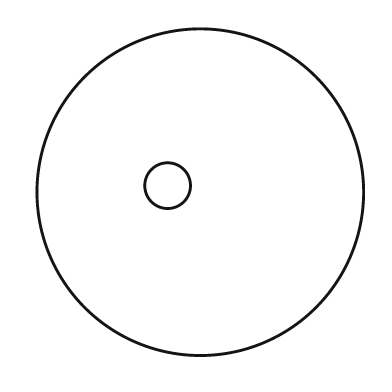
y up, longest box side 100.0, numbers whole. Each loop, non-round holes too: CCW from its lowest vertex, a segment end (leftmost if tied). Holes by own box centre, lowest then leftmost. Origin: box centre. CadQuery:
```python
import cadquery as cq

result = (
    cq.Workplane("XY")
    .moveTo(0.0, 0.0)
    .circle(50.0)
    .moveTo(-10.0, 2.0)
    .circle(7.0)
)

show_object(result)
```